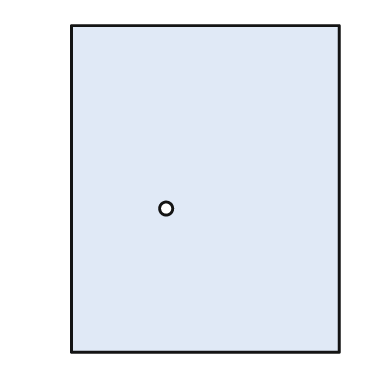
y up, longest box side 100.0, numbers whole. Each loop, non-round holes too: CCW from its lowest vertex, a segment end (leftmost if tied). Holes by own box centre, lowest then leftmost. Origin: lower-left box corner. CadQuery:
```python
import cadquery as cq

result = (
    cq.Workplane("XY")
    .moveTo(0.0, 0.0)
    .lineTo(82.0, 0.0)
    .lineTo(82.0, 100.0)
    .lineTo(0.0, 100.0)
    .close()
    .moveTo(29.0, 44.0)
    .circle(2.0)
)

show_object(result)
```